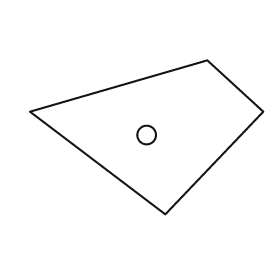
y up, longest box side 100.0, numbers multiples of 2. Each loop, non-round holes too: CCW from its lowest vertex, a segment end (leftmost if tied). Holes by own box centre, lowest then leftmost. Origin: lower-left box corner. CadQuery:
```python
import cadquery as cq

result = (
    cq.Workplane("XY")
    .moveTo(58.0, 0.0)
    .lineTo(100.0, 44.0)
    .lineTo(76.0, 66.0)
    .lineTo(0.0, 44.0)
    .close()
    .moveTo(50.0, 34.0)
    .circle(4.0)
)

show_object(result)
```